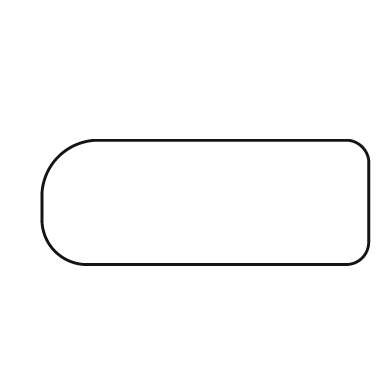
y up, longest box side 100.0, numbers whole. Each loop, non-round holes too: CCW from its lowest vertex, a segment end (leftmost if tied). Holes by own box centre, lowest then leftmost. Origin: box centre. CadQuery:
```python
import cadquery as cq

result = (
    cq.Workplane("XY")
    .moveTo(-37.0, -19.0)
    .lineTo(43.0, -19.0)
    .threePointArc((48.0, -17.0), (50.0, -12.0))
    .lineTo(50.0, 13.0)
    .threePointArc((48.0, 17.0), (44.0, 19.0))
    .lineTo(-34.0, 19.0)
    .threePointArc((-45.0, 14.0), (-50.0, 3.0))
    .lineTo(-50.0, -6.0)
    .threePointArc((-46.0, -15.0), (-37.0, -19.0))
    .close()
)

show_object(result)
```